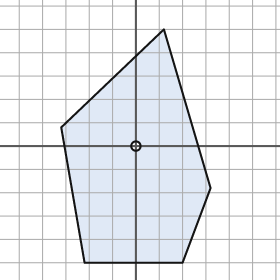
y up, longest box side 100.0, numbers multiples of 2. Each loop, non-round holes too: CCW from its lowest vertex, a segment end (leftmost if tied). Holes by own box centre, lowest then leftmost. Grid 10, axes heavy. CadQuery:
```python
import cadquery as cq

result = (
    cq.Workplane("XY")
    .moveTo(-22.0, -50.0)
    .lineTo(20.0, -50.0)
    .lineTo(32.0, -18.0)
    .lineTo(12.0, 50.0)
    .lineTo(-32.0, 8.0)
    .close()
    .moveTo(0.0, 0.0)
    .circle(2.0)
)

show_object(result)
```